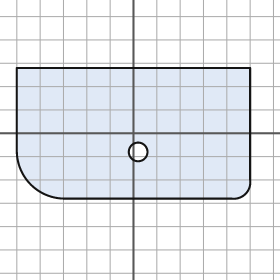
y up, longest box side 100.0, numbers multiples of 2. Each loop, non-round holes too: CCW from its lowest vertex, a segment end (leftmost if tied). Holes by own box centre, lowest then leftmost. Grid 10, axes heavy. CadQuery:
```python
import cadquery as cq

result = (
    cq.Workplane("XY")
    .moveTo(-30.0, -28.0)
    .lineTo(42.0, -28.0)
    .threePointArc((48.0, -26.0), (50.0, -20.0))
    .lineTo(50.0, 28.0)
    .lineTo(-50.0, 28.0)
    .lineTo(-50.0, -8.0)
    .threePointArc((-44.0, -22.0), (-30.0, -28.0))
    .close()
    .moveTo(2.0, -8.0)
    .circle(4.0)
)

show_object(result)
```